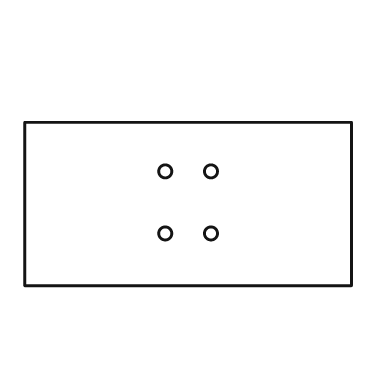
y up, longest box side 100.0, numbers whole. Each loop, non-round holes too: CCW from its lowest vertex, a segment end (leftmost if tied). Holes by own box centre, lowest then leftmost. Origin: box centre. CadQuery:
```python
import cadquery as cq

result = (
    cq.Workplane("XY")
    .moveTo(-50.0, -25.0)
    .lineTo(50.0, -25.0)
    .lineTo(50.0, 25.0)
    .lineTo(-50.0, 25.0)
    .close()
    .moveTo(-7.0, -9.0)
    .circle(2.0)
    .moveTo(7.0, -9.0)
    .circle(2.0)
    .moveTo(-7.0, 10.0)
    .circle(2.0)
    .moveTo(7.0, 10.0)
    .circle(2.0)
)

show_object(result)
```